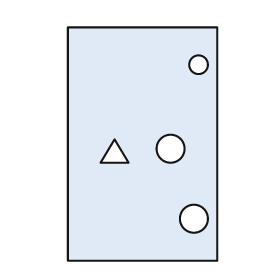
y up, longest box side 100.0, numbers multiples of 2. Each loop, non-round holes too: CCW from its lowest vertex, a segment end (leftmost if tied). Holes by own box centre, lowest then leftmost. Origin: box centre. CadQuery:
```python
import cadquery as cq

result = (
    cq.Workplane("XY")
    .moveTo(-32.0, -50.0)
    .lineTo(32.0, -50.0)
    .lineTo(32.0, 50.0)
    .lineTo(-32.0, 50.0)
    .close()
    .moveTo(22.0, -32.0)
    .circle(6.0)
    .moveTo(-18.0, -8.0)
    .lineTo(-6.0, -8.0)
    .lineTo(-12.0, 2.0)
    .close()
    .moveTo(12.0, -2.0)
    .circle(6.0)
    .moveTo(24.0, 34.0)
    .circle(4.0)
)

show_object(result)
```